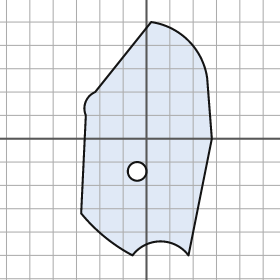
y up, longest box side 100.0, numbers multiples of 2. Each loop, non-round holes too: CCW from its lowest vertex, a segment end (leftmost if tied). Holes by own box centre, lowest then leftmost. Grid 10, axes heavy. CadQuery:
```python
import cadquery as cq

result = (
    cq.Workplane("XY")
    .moveTo(-6.0, -50.0)
    .threePointArc((6.0, -44.0), (18.0, -50.0))
    .lineTo(28.0, 0.0)
    .lineTo(26.0, 26.0)
    .threePointArc((18.0, 42.0), (2.0, 50.0))
    .lineTo(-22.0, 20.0)
    .threePointArc((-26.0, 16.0), (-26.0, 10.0))
    .lineTo(-28.0, -32.0)
    .threePointArc((-18.0, -42.0), (-6.0, -50.0))
    .close()
    .moveTo(-4.0, -14.0)
    .circle(4.0)
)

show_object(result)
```